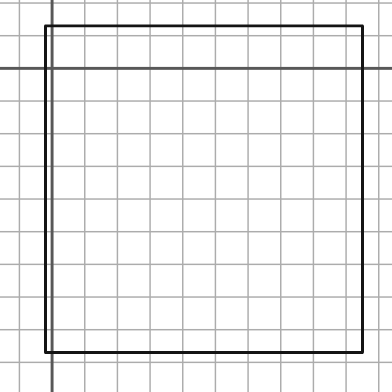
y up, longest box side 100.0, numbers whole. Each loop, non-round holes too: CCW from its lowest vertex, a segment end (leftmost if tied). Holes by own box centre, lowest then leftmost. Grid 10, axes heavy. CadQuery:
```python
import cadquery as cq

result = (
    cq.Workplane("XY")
    .moveTo(-2.0, -87.0)
    .lineTo(95.0, -87.0)
    .lineTo(95.0, 13.0)
    .lineTo(-2.0, 13.0)
    .close()
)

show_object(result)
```